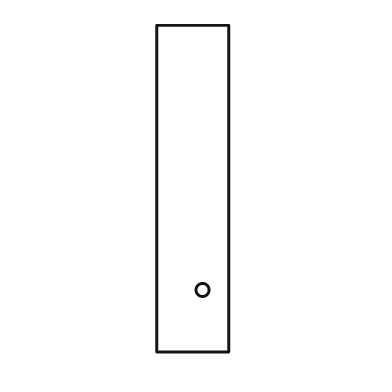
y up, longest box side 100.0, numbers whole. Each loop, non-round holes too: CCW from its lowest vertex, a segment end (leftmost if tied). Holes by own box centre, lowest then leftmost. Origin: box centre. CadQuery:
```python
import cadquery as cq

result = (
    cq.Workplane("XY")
    .moveTo(-11.0, -50.0)
    .lineTo(11.0, -50.0)
    .lineTo(11.0, 50.0)
    .lineTo(-11.0, 50.0)
    .close()
    .moveTo(3.0, -31.0)
    .circle(2.0)
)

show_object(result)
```